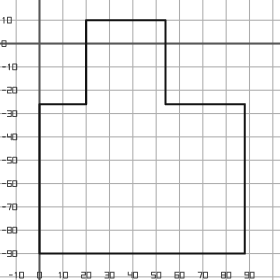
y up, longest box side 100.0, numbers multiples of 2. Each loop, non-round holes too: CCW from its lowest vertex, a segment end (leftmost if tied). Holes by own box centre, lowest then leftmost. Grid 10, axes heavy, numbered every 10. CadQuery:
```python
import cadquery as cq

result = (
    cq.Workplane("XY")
    .moveTo(0.0, -90.0)
    .lineTo(88.0, -90.0)
    .lineTo(88.0, -26.0)
    .lineTo(54.0, -26.0)
    .lineTo(54.0, 10.0)
    .lineTo(20.0, 10.0)
    .lineTo(20.0, -26.0)
    .lineTo(0.0, -26.0)
    .close()
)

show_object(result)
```